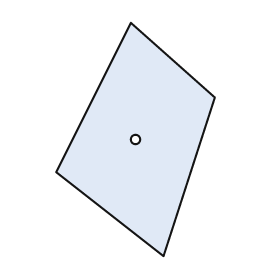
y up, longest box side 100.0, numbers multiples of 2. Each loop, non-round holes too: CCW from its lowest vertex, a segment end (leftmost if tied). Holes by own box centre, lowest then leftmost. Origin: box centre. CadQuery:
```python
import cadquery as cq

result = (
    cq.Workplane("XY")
    .moveTo(12.0, -50.0)
    .lineTo(34.0, 18.0)
    .lineTo(-2.0, 50.0)
    .lineTo(-34.0, -14.0)
    .close()
    .moveTo(0.0, 0.0)
    .circle(2.0)
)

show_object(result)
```